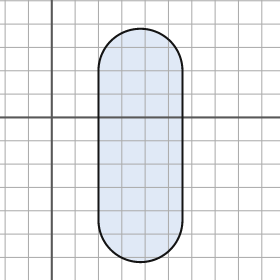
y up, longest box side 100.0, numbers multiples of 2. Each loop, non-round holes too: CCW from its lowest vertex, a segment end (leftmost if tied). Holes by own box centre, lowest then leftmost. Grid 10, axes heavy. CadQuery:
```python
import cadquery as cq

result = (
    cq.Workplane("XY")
    .moveTo(20.0, -44.0)
    .threePointArc((38.0, -62.0), (56.0, -44.0))
    .lineTo(56.0, 20.0)
    .threePointArc((38.0, 38.0), (20.0, 20.0))
    .close()
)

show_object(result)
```